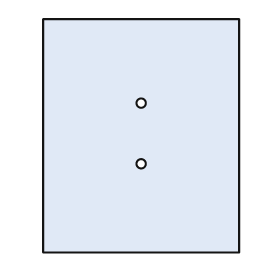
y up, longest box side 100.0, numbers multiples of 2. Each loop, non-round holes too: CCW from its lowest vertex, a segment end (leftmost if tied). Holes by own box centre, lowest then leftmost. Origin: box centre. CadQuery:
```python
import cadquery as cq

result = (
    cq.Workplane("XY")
    .moveTo(-42.0, -50.0)
    .lineTo(42.0, -50.0)
    .lineTo(42.0, 50.0)
    .lineTo(-42.0, 50.0)
    .close()
    .moveTo(0.0, -12.0)
    .circle(2.0)
    .moveTo(0.0, 14.0)
    .circle(2.0)
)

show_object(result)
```